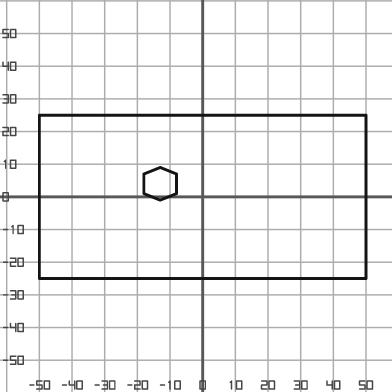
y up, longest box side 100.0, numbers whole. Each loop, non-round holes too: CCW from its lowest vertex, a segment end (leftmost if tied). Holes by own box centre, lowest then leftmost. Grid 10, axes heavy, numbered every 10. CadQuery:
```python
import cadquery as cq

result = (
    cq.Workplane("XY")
    .moveTo(-50.0, -25.0)
    .lineTo(50.0, -25.0)
    .lineTo(50.0, 25.0)
    .lineTo(-50.0, 25.0)
    .close()
    .moveTo(-13.0, -1.0)
    .lineTo(-8.0, 1.0)
    .lineTo(-8.0, 7.0)
    .lineTo(-13.0, 9.0)
    .lineTo(-18.0, 7.0)
    .lineTo(-18.0, 1.0)
    .close()
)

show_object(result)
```